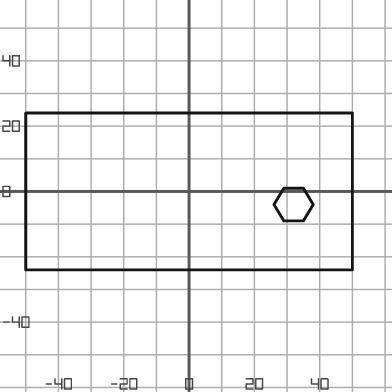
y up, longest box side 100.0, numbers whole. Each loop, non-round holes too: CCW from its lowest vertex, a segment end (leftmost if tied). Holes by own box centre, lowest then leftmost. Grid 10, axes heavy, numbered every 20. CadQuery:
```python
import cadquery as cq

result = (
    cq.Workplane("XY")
    .moveTo(-50.0, -24.0)
    .lineTo(50.0, -24.0)
    .lineTo(50.0, 24.0)
    .lineTo(-50.0, 24.0)
    .close()
    .moveTo(29.0, -9.0)
    .lineTo(35.0, -9.0)
    .lineTo(38.0, -4.0)
    .lineTo(35.0, 1.0)
    .lineTo(29.0, 1.0)
    .lineTo(26.0, -4.0)
    .close()
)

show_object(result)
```